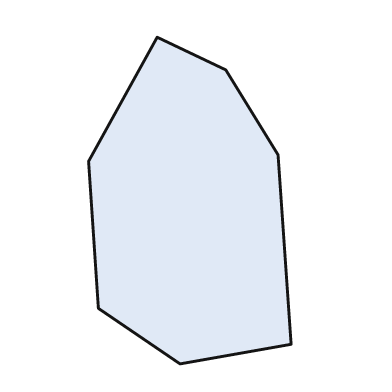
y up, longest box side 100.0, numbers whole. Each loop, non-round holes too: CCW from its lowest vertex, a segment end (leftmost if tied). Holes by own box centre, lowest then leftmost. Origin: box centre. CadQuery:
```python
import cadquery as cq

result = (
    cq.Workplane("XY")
    .moveTo(-3.0, -50.0)
    .lineTo(31.0, -44.0)
    .lineTo(27.0, 14.0)
    .lineTo(11.0, 40.0)
    .lineTo(-10.0, 50.0)
    .lineTo(-31.0, 12.0)
    .lineTo(-28.0, -33.0)
    .close()
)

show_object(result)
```